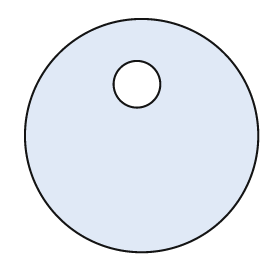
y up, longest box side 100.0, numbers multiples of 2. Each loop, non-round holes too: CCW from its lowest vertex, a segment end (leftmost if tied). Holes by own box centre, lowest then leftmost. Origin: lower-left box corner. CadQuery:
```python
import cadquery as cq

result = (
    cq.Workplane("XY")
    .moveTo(50.0, 50.0)
    .circle(50.0)
    .moveTo(48.0, 72.0)
    .circle(10.0)
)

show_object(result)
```